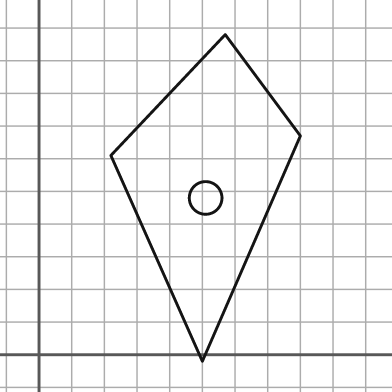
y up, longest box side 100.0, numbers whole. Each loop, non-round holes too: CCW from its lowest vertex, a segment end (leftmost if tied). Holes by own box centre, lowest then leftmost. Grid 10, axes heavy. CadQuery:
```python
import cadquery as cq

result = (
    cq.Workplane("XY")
    .moveTo(50.0, -2.0)
    .lineTo(80.0, 67.0)
    .lineTo(57.0, 98.0)
    .lineTo(22.0, 61.0)
    .close()
    .moveTo(51.0, 48.0)
    .circle(5.0)
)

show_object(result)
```